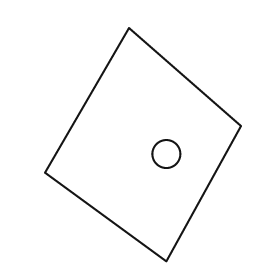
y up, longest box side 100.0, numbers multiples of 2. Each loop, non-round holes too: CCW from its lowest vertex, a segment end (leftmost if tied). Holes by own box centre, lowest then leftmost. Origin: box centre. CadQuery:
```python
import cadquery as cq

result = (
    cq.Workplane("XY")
    .moveTo(10.0, -50.0)
    .lineTo(42.0, 8.0)
    .lineTo(-6.0, 50.0)
    .lineTo(-42.0, -12.0)
    .close()
    .moveTo(10.0, -4.0)
    .circle(6.0)
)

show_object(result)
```